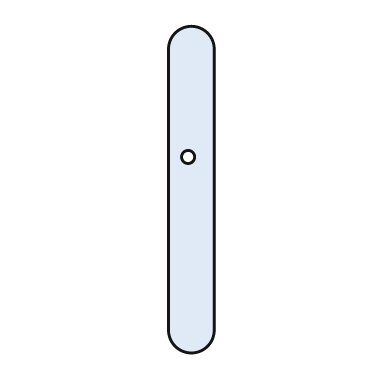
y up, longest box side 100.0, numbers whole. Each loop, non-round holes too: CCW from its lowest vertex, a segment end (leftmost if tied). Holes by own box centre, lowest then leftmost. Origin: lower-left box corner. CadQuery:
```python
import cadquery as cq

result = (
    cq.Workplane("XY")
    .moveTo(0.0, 7.0)
    .threePointArc((7.0, 0.0), (14.0, 7.0))
    .lineTo(14.0, 93.0)
    .threePointArc((7.0, 100.0), (0.0, 93.0))
    .close()
    .moveTo(6.0, 60.0)
    .circle(2.0)
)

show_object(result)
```